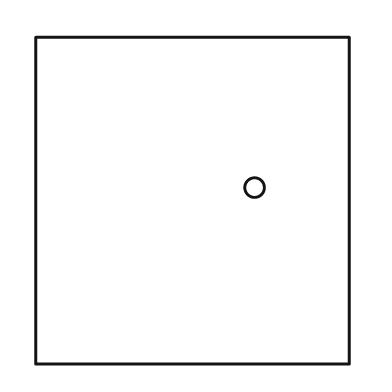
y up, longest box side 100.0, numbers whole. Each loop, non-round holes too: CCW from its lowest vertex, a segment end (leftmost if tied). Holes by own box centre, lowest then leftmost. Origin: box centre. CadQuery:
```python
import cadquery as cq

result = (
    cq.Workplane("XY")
    .moveTo(-48.0, -50.0)
    .lineTo(48.0, -50.0)
    .lineTo(48.0, 50.0)
    .lineTo(-48.0, 50.0)
    .close()
    .moveTo(19.0, 4.0)
    .circle(3.0)
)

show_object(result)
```